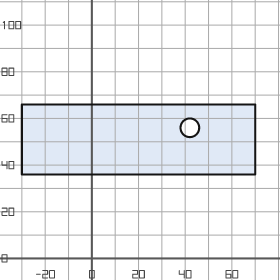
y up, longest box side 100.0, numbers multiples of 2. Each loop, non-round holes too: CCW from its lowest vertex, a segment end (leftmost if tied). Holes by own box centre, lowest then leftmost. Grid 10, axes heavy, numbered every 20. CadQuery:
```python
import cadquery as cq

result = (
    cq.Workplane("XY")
    .moveTo(-30.0, 36.0)
    .lineTo(70.0, 36.0)
    .lineTo(70.0, 66.0)
    .lineTo(-30.0, 66.0)
    .close()
    .moveTo(42.0, 56.0)
    .circle(4.0)
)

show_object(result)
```